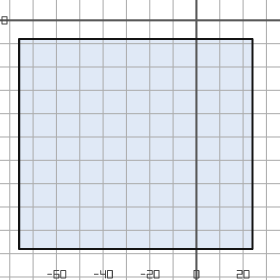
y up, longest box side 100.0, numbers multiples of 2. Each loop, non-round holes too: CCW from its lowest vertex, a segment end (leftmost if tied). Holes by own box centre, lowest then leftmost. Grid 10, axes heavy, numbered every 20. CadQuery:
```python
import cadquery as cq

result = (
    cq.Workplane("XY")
    .moveTo(-76.0, -98.0)
    .lineTo(24.0, -98.0)
    .lineTo(24.0, -8.0)
    .lineTo(-76.0, -8.0)
    .close()
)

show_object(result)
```